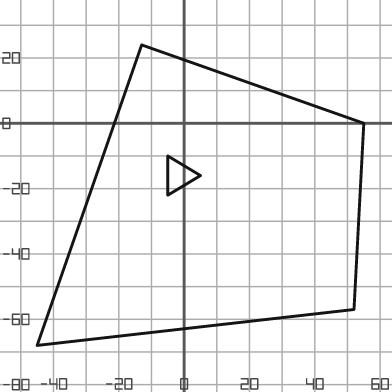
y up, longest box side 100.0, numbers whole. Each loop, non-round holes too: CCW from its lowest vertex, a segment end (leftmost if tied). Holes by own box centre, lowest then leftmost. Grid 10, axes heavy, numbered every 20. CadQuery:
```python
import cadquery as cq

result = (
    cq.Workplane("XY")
    .moveTo(-45.0, -68.0)
    .lineTo(52.0, -57.0)
    .lineTo(55.0, 0.0)
    .lineTo(-13.0, 24.0)
    .close()
    .moveTo(-5.0, -22.0)
    .lineTo(5.0, -16.0)
    .lineTo(-5.0, -10.0)
    .close()
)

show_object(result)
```